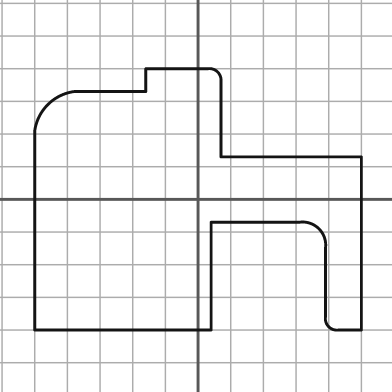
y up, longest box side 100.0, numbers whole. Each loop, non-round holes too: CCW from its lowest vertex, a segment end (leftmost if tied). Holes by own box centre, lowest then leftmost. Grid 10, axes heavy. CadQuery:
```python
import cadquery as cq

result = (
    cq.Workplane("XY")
    .moveTo(-50.0, -40.0)
    .lineTo(4.0, -40.0)
    .lineTo(4.0, -7.0)
    .lineTo(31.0, -7.0)
    .threePointArc((37.0, -9.0), (39.0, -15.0))
    .lineTo(39.0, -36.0)
    .threePointArc((40.0, -39.0), (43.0, -40.0))
    .lineTo(50.0, -40.0)
    .lineTo(50.0, 13.0)
    .lineTo(7.0, 13.0)
    .lineTo(7.0, 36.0)
    .threePointArc((6.0, 39.0), (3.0, 40.0))
    .lineTo(-16.0, 40.0)
    .lineTo(-16.0, 33.0)
    .lineTo(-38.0, 33.0)
    .threePointArc((-46.0, 29.0), (-50.0, 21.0))
    .close()
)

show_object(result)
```